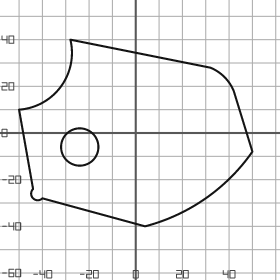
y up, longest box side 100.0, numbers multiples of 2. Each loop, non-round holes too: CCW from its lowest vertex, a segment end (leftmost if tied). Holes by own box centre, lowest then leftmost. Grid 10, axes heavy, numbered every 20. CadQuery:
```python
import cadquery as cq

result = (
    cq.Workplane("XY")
    .moveTo(4.0, -40.0)
    .threePointArc((30.0, -28.0), (50.0, -8.0))
    .lineTo(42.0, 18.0)
    .threePointArc((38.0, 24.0), (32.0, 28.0))
    .lineTo(-28.0, 40.0)
    .threePointArc((-32.0, 20.0), (-50.0, 10.0))
    .lineTo(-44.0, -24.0)
    .threePointArc((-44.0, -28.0), (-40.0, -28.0))
    .close()
    .moveTo(-24.0, -6.0)
    .circle(8.0)
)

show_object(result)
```